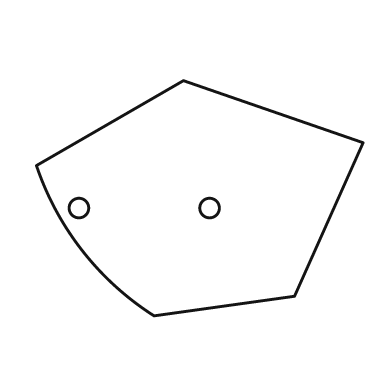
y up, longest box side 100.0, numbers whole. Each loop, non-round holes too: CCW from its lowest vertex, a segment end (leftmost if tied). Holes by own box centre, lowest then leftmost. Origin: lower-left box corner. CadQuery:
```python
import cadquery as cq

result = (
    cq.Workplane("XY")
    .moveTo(36.0, 0.0)
    .lineTo(79.0, 6.0)
    .lineTo(100.0, 53.0)
    .lineTo(45.0, 72.0)
    .lineTo(0.0, 46.0)
    .threePointArc((14.0, 20.0), (36.0, 0.0))
    .close()
    .moveTo(13.0, 33.0)
    .circle(3.0)
    .moveTo(53.0, 33.0)
    .circle(3.0)
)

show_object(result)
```